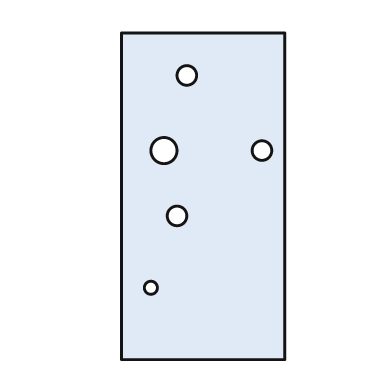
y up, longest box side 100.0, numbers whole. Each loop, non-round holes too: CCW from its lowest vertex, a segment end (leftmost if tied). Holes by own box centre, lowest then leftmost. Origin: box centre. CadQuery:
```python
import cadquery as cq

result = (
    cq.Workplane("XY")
    .moveTo(-25.0, -50.0)
    .lineTo(25.0, -50.0)
    .lineTo(25.0, 50.0)
    .lineTo(-25.0, 50.0)
    .close()
    .moveTo(-16.0, -28.0)
    .circle(2.0)
    .moveTo(-8.0, -6.0)
    .circle(3.0)
    .moveTo(-12.0, 14.0)
    .circle(4.0)
    .moveTo(18.0, 14.0)
    .circle(3.0)
    .moveTo(-5.0, 37.0)
    .circle(3.0)
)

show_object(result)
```